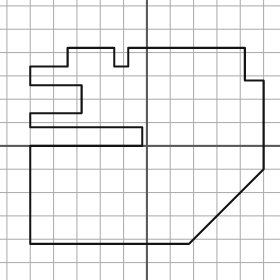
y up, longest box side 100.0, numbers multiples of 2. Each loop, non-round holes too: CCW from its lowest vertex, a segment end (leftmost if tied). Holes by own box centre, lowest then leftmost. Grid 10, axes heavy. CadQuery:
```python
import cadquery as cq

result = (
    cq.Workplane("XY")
    .moveTo(-50.0, -42.0)
    .lineTo(18.0, -42.0)
    .lineTo(50.0, -10.0)
    .lineTo(50.0, 28.0)
    .lineTo(42.0, 28.0)
    .lineTo(42.0, 42.0)
    .lineTo(-8.0, 42.0)
    .lineTo(-8.0, 34.0)
    .lineTo(-14.0, 34.0)
    .lineTo(-14.0, 42.0)
    .lineTo(-34.0, 42.0)
    .lineTo(-34.0, 34.0)
    .lineTo(-50.0, 34.0)
    .lineTo(-50.0, 26.0)
    .lineTo(-28.0, 26.0)
    .lineTo(-28.0, 14.0)
    .lineTo(-50.0, 14.0)
    .lineTo(-50.0, 8.0)
    .lineTo(-2.0, 8.0)
    .lineTo(-2.0, 0.0)
    .lineTo(-50.0, 0.0)
    .close()
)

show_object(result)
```